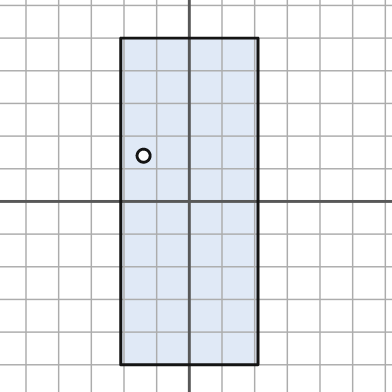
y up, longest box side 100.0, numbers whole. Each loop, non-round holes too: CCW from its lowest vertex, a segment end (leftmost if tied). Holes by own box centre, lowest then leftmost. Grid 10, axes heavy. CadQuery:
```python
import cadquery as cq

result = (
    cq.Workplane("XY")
    .moveTo(-21.0, -50.0)
    .lineTo(21.0, -50.0)
    .lineTo(21.0, 50.0)
    .lineTo(-21.0, 50.0)
    .close()
    .moveTo(-14.0, 14.0)
    .circle(2.0)
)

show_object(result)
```